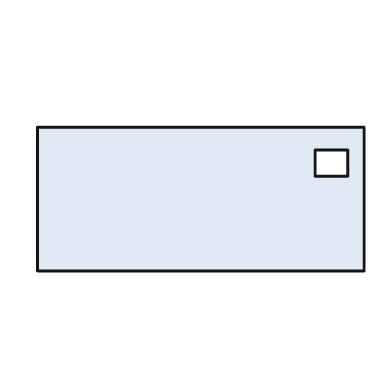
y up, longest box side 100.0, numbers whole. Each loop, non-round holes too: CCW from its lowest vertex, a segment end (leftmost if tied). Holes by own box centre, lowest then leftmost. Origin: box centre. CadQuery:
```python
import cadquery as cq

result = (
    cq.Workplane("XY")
    .moveTo(-50.0, -22.0)
    .lineTo(50.0, -22.0)
    .lineTo(50.0, 22.0)
    .lineTo(-50.0, 22.0)
    .close()
    .moveTo(35.0, 7.0)
    .lineTo(45.0, 7.0)
    .lineTo(45.0, 15.0)
    .lineTo(35.0, 15.0)
    .close()
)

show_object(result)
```